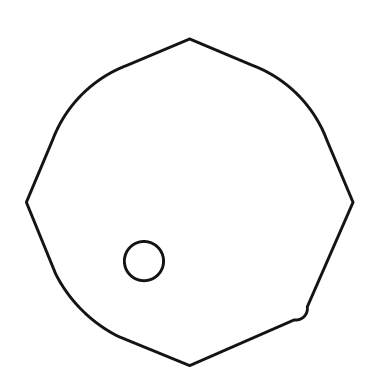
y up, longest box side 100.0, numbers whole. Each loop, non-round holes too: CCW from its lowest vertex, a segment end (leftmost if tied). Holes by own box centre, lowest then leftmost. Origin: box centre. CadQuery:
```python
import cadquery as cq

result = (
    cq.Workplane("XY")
    .moveTo(0.0, -50.0)
    .lineTo(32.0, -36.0)
    .threePointArc((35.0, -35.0), (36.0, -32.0))
    .lineTo(50.0, 0.0)
    .lineTo(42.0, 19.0)
    .threePointArc((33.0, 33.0), (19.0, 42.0))
    .lineTo(0.0, 50.0)
    .lineTo(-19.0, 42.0)
    .threePointArc((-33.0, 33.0), (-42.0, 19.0))
    .lineTo(-50.0, 0.0)
    .lineTo(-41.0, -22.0)
    .threePointArc((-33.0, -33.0), (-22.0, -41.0))
    .close()
    .moveTo(-14.0, -18.0)
    .circle(6.0)
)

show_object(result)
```